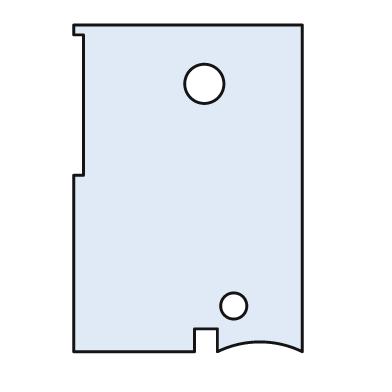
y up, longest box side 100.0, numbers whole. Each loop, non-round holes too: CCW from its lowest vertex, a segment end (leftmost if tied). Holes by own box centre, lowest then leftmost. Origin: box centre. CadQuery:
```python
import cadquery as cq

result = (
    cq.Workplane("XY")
    .moveTo(-35.0, -50.0)
    .lineTo(2.0, -50.0)
    .lineTo(2.0, -43.0)
    .lineTo(9.0, -43.0)
    .lineTo(9.0, -50.0)
    .threePointArc((22.0, -47.0), (35.0, -50.0))
    .lineTo(35.0, 50.0)
    .lineTo(-35.0, 50.0)
    .lineTo(-35.0, 47.0)
    .lineTo(-32.0, 47.0)
    .lineTo(-32.0, 4.0)
    .lineTo(-35.0, 4.0)
    .close()
    .moveTo(14.0, -36.0)
    .circle(4.0)
    .moveTo(5.0, 32.0)
    .circle(6.0)
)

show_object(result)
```